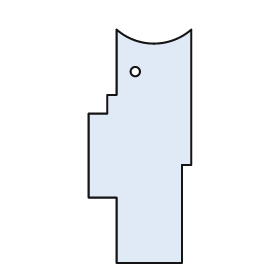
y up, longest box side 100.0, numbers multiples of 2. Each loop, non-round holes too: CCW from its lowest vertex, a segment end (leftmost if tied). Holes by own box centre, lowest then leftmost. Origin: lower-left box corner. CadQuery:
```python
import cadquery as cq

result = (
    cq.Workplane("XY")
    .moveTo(12.0, 0.0)
    .lineTo(40.0, 0.0)
    .lineTo(40.0, 42.0)
    .lineTo(44.0, 42.0)
    .lineTo(44.0, 100.0)
    .threePointArc((28.0, 94.0), (12.0, 100.0))
    .lineTo(12.0, 72.0)
    .lineTo(8.0, 72.0)
    .lineTo(8.0, 64.0)
    .lineTo(0.0, 64.0)
    .lineTo(0.0, 28.0)
    .lineTo(12.0, 28.0)
    .close()
    .moveTo(20.0, 82.0)
    .circle(2.0)
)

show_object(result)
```